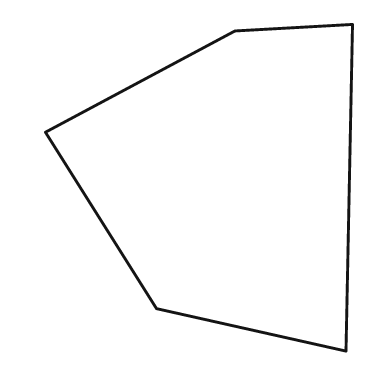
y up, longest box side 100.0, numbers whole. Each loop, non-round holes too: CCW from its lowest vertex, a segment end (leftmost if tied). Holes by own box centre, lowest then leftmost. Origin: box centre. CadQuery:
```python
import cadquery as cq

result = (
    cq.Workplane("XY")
    .moveTo(45.0, -50.0)
    .lineTo(47.0, 50.0)
    .lineTo(11.0, 48.0)
    .lineTo(-47.0, 17.0)
    .lineTo(-13.0, -37.0)
    .close()
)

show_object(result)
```